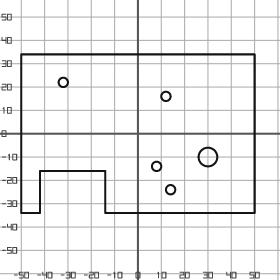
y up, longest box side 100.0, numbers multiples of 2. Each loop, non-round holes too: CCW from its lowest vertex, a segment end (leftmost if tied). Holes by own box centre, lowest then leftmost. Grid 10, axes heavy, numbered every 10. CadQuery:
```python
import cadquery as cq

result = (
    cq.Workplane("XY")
    .moveTo(-50.0, -34.0)
    .lineTo(-42.0, -34.0)
    .lineTo(-42.0, -16.0)
    .lineTo(-14.0, -16.0)
    .lineTo(-14.0, -34.0)
    .lineTo(50.0, -34.0)
    .lineTo(50.0, 34.0)
    .lineTo(-50.0, 34.0)
    .close()
    .moveTo(14.0, -24.0)
    .circle(2.0)
    .moveTo(8.0, -14.0)
    .circle(2.0)
    .moveTo(30.0, -10.0)
    .circle(4.0)
    .moveTo(12.0, 16.0)
    .circle(2.0)
    .moveTo(-32.0, 22.0)
    .circle(2.0)
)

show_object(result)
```